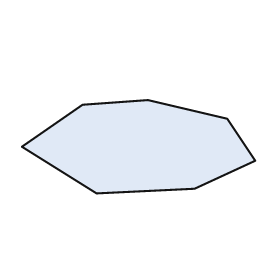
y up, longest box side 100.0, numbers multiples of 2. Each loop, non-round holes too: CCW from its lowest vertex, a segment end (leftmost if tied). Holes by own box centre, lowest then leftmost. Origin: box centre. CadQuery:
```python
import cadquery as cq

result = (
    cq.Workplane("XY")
    .moveTo(-18.0, -20.0)
    .lineTo(24.0, -18.0)
    .lineTo(50.0, -6.0)
    .lineTo(38.0, 12.0)
    .lineTo(4.0, 20.0)
    .lineTo(-24.0, 18.0)
    .lineTo(-50.0, 0.0)
    .close()
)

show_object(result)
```